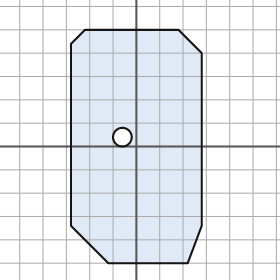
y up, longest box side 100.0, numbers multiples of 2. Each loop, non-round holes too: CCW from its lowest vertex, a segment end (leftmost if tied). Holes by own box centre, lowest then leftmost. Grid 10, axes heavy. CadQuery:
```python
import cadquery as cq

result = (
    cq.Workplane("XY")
    .moveTo(-12.0, -50.0)
    .lineTo(22.0, -50.0)
    .lineTo(28.0, -34.0)
    .lineTo(28.0, 40.0)
    .lineTo(18.0, 50.0)
    .lineTo(-22.0, 50.0)
    .lineTo(-28.0, 44.0)
    .lineTo(-28.0, -34.0)
    .close()
    .moveTo(-6.0, 4.0)
    .circle(4.0)
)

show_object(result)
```